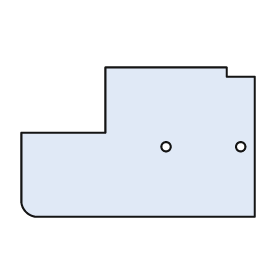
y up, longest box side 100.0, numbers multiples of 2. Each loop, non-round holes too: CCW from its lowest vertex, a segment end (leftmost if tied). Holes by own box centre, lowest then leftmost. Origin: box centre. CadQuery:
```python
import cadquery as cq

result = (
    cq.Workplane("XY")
    .moveTo(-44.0, -32.0)
    .lineTo(50.0, -32.0)
    .lineTo(50.0, 28.0)
    .lineTo(38.0, 28.0)
    .lineTo(38.0, 32.0)
    .lineTo(-14.0, 32.0)
    .lineTo(-14.0, 4.0)
    .lineTo(-50.0, 4.0)
    .lineTo(-50.0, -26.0)
    .threePointArc((-48.0, -30.0), (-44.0, -32.0))
    .close()
    .moveTo(12.0, -2.0)
    .circle(2.0)
    .moveTo(44.0, -2.0)
    .circle(2.0)
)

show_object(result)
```